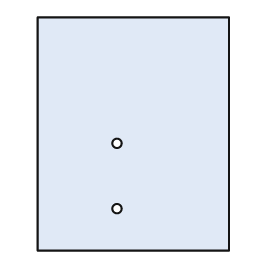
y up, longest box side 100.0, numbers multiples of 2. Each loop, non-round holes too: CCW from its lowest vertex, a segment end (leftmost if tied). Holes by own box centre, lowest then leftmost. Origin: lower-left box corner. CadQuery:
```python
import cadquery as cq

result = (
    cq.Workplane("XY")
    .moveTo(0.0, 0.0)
    .lineTo(82.0, 0.0)
    .lineTo(82.0, 100.0)
    .lineTo(0.0, 100.0)
    .close()
    .moveTo(34.0, 18.0)
    .circle(2.0)
    .moveTo(34.0, 46.0)
    .circle(2.0)
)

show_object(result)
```